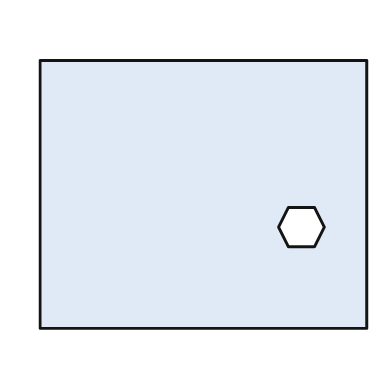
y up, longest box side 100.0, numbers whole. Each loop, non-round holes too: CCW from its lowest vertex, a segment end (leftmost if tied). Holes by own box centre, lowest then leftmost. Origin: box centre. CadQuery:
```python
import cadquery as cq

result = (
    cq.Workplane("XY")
    .moveTo(-50.0, -41.0)
    .lineTo(50.0, -41.0)
    .lineTo(50.0, 41.0)
    .lineTo(-50.0, 41.0)
    .close()
    .moveTo(26.0, -16.0)
    .lineTo(34.0, -16.0)
    .lineTo(37.0, -10.0)
    .lineTo(34.0, -4.0)
    .lineTo(26.0, -4.0)
    .lineTo(23.0, -10.0)
    .close()
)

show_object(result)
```